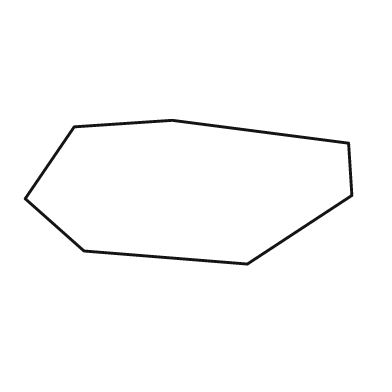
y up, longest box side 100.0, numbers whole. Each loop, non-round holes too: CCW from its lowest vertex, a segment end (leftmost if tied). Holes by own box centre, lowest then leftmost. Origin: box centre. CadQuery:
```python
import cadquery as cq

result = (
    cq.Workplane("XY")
    .moveTo(18.0, -22.0)
    .lineTo(50.0, -1.0)
    .lineTo(49.0, 15.0)
    .lineTo(-5.0, 22.0)
    .lineTo(-35.0, 20.0)
    .lineTo(-50.0, -2.0)
    .lineTo(-32.0, -18.0)
    .close()
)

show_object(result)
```